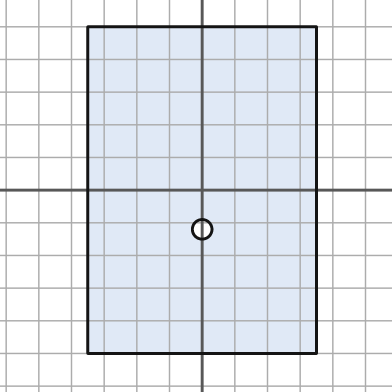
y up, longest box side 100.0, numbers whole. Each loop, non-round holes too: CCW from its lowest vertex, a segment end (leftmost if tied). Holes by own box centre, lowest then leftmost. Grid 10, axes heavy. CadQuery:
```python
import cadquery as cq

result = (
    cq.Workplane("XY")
    .moveTo(-35.0, -50.0)
    .lineTo(35.0, -50.0)
    .lineTo(35.0, 50.0)
    .lineTo(-35.0, 50.0)
    .close()
    .moveTo(0.0, -12.0)
    .circle(3.0)
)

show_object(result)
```